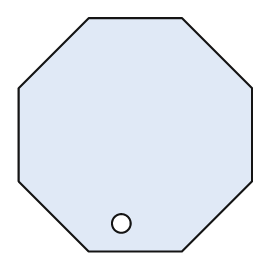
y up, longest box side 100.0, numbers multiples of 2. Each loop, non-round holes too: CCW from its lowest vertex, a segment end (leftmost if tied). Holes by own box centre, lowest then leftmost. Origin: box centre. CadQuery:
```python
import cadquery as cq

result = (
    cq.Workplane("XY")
    .moveTo(-20.0, -50.0)
    .lineTo(20.0, -50.0)
    .lineTo(50.0, -20.0)
    .lineTo(50.0, 20.0)
    .lineTo(20.0, 50.0)
    .lineTo(-20.0, 50.0)
    .lineTo(-50.0, 20.0)
    .lineTo(-50.0, -20.0)
    .close()
    .moveTo(-6.0, -38.0)
    .circle(4.0)
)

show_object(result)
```